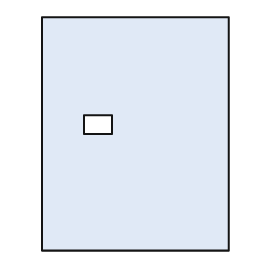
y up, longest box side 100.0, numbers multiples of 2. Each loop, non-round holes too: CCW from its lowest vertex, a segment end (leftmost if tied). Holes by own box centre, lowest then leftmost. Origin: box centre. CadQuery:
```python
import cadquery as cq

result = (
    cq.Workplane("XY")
    .moveTo(-40.0, -50.0)
    .lineTo(40.0, -50.0)
    .lineTo(40.0, 50.0)
    .lineTo(-40.0, 50.0)
    .close()
    .moveTo(-22.0, 0.0)
    .lineTo(-10.0, 0.0)
    .lineTo(-10.0, 8.0)
    .lineTo(-22.0, 8.0)
    .close()
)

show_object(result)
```